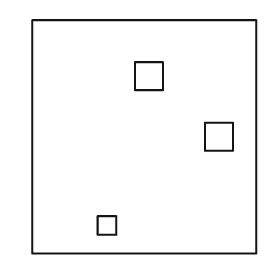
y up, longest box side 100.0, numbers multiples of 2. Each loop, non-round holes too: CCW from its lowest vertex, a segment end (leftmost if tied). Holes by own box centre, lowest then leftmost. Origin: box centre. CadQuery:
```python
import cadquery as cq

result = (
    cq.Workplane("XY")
    .moveTo(-48.0, -50.0)
    .lineTo(48.0, -50.0)
    .lineTo(48.0, 50.0)
    .lineTo(-48.0, 50.0)
    .close()
    .moveTo(-20.0, -42.0)
    .lineTo(-12.0, -42.0)
    .lineTo(-12.0, -34.0)
    .lineTo(-20.0, -34.0)
    .close()
    .moveTo(26.0, -6.0)
    .lineTo(38.0, -6.0)
    .lineTo(38.0, 6.0)
    .lineTo(26.0, 6.0)
    .close()
    .moveTo(-4.0, 20.0)
    .lineTo(8.0, 20.0)
    .lineTo(8.0, 32.0)
    .lineTo(-4.0, 32.0)
    .close()
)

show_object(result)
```